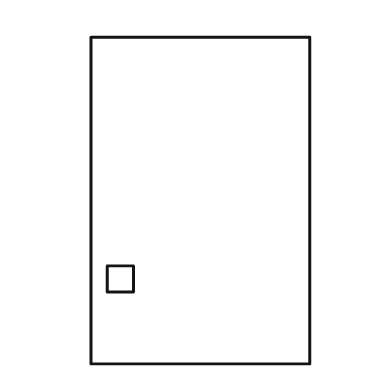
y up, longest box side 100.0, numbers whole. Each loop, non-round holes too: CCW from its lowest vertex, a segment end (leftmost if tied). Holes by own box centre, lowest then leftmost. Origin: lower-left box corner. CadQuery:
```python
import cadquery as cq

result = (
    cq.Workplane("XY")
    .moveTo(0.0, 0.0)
    .lineTo(67.0, 0.0)
    .lineTo(67.0, 100.0)
    .lineTo(0.0, 100.0)
    .close()
    .moveTo(5.0, 22.0)
    .lineTo(13.0, 22.0)
    .lineTo(13.0, 30.0)
    .lineTo(5.0, 30.0)
    .close()
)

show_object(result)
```